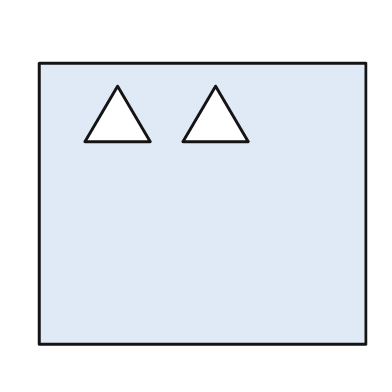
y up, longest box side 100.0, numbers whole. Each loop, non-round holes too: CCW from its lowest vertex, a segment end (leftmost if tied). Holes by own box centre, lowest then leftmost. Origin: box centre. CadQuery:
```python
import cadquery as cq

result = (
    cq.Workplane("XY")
    .moveTo(-50.0, -43.0)
    .lineTo(50.0, -43.0)
    .lineTo(50.0, 43.0)
    .lineTo(-50.0, 43.0)
    .close()
    .moveTo(-36.0, 19.0)
    .lineTo(-16.0, 19.0)
    .lineTo(-26.0, 36.0)
    .close()
    .moveTo(-6.0, 19.0)
    .lineTo(14.0, 19.0)
    .lineTo(4.0, 36.0)
    .close()
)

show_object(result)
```